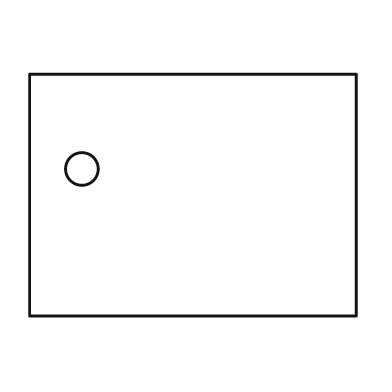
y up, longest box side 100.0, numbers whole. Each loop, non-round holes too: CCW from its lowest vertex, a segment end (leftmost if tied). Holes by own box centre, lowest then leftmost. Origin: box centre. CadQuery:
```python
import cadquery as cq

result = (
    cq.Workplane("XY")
    .moveTo(-50.0, -37.0)
    .lineTo(50.0, -37.0)
    .lineTo(50.0, 37.0)
    .lineTo(-50.0, 37.0)
    .close()
    .moveTo(-34.0, 8.0)
    .circle(5.0)
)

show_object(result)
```